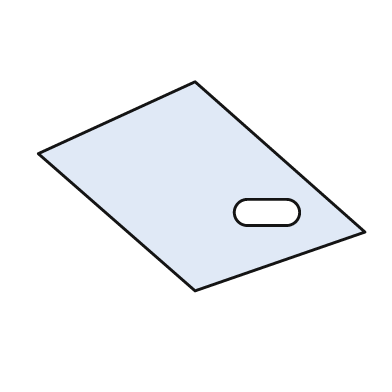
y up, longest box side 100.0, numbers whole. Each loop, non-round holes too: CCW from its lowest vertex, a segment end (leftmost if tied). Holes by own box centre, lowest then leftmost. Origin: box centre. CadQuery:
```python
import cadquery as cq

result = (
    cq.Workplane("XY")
    .moveTo(-2.0, -32.0)
    .lineTo(50.0, -14.0)
    .lineTo(-2.0, 32.0)
    .lineTo(-50.0, 10.0)
    .close()
    .moveTo(14.0, -12.0)
    .lineTo(26.0, -12.0)
    .threePointArc((30.0, -8.0), (26.0, -4.0))
    .lineTo(14.0, -4.0)
    .threePointArc((10.0, -8.0), (14.0, -12.0))
    .close()
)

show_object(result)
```